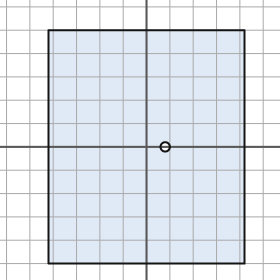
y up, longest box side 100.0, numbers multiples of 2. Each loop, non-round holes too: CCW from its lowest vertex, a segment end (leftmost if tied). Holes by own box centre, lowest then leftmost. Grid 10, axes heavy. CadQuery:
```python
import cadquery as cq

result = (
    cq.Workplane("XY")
    .moveTo(-42.0, -50.0)
    .lineTo(42.0, -50.0)
    .lineTo(42.0, 50.0)
    .lineTo(-42.0, 50.0)
    .close()
    .moveTo(8.0, 0.0)
    .circle(2.0)
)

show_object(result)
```